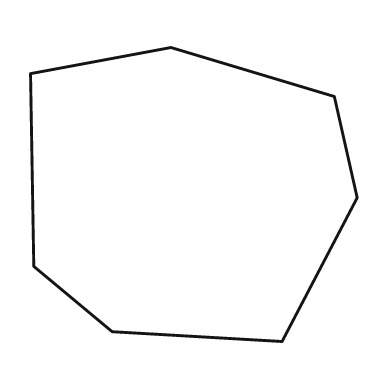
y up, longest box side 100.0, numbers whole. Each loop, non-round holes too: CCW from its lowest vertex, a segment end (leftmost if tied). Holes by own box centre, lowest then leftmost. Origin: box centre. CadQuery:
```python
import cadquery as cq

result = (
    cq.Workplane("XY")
    .moveTo(27.0, -45.0)
    .lineTo(50.0, -1.0)
    .lineTo(43.0, 30.0)
    .lineTo(-7.0, 45.0)
    .lineTo(-50.0, 37.0)
    .lineTo(-49.0, -22.0)
    .lineTo(-25.0, -42.0)
    .close()
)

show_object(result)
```